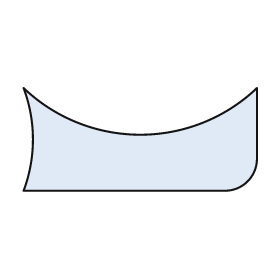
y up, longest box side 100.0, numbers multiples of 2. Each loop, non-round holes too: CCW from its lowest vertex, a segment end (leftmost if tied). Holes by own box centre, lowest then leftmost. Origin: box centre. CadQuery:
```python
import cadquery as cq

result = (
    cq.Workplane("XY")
    .moveTo(-50.0, -22.0)
    .lineTo(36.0, -22.0)
    .threePointArc((46.0, -18.0), (50.0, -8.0))
    .lineTo(50.0, 22.0)
    .threePointArc((0.0, 2.0), (-50.0, 22.0))
    .threePointArc((-46.0, 0.0), (-50.0, -22.0))
    .close()
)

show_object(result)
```